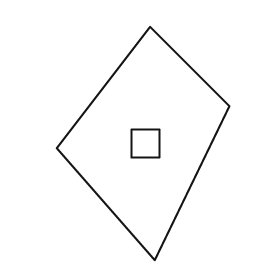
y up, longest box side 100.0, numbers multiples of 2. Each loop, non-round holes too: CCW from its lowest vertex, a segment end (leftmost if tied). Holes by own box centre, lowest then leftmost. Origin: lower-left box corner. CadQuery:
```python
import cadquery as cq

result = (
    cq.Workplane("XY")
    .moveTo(42.0, 0.0)
    .lineTo(74.0, 66.0)
    .lineTo(40.0, 100.0)
    .lineTo(0.0, 48.0)
    .close()
    .moveTo(32.0, 44.0)
    .lineTo(44.0, 44.0)
    .lineTo(44.0, 56.0)
    .lineTo(32.0, 56.0)
    .close()
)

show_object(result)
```